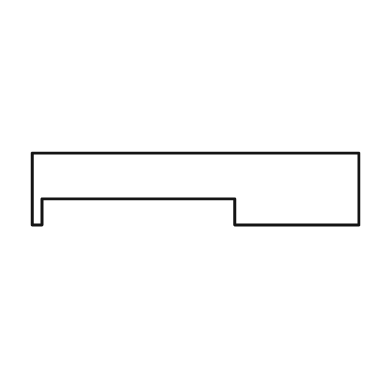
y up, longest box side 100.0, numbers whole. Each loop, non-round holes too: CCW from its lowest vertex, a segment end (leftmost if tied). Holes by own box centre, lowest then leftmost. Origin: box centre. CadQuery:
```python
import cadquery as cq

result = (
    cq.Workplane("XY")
    .moveTo(-50.0, -11.0)
    .lineTo(-47.0, -11.0)
    .lineTo(-47.0, -3.0)
    .lineTo(12.0, -3.0)
    .lineTo(12.0, -11.0)
    .lineTo(50.0, -11.0)
    .lineTo(50.0, 11.0)
    .lineTo(-50.0, 11.0)
    .close()
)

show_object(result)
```